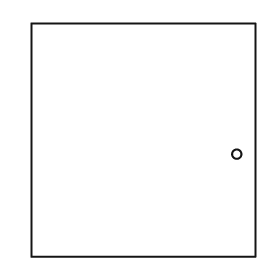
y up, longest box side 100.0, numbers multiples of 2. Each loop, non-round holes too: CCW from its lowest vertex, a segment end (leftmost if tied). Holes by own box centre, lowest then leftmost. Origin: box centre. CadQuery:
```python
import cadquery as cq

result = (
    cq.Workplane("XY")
    .moveTo(-48.0, -50.0)
    .lineTo(48.0, -50.0)
    .lineTo(48.0, 50.0)
    .lineTo(-48.0, 50.0)
    .close()
    .moveTo(40.0, -6.0)
    .circle(2.0)
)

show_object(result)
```